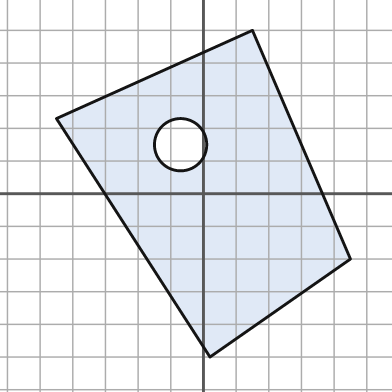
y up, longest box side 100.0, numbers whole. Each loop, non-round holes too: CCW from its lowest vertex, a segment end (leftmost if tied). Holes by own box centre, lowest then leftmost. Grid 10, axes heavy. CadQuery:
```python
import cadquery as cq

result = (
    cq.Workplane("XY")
    .moveTo(2.0, -50.0)
    .lineTo(45.0, -20.0)
    .lineTo(15.0, 50.0)
    .lineTo(-45.0, 23.0)
    .close()
    .moveTo(-7.0, 15.0)
    .circle(8.0)
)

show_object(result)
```